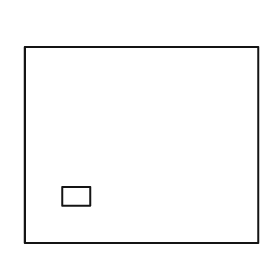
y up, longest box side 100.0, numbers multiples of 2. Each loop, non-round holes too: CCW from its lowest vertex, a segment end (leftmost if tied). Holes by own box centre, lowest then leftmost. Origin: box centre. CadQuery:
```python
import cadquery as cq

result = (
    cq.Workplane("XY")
    .moveTo(-50.0, -42.0)
    .lineTo(50.0, -42.0)
    .lineTo(50.0, 42.0)
    .lineTo(-50.0, 42.0)
    .close()
    .moveTo(-34.0, -26.0)
    .lineTo(-22.0, -26.0)
    .lineTo(-22.0, -18.0)
    .lineTo(-34.0, -18.0)
    .close()
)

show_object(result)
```